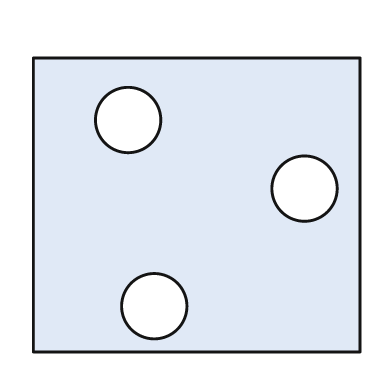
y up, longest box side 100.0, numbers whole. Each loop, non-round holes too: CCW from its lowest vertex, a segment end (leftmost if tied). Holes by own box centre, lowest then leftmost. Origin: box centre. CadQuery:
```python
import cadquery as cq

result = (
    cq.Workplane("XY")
    .moveTo(-50.0, -45.0)
    .lineTo(50.0, -45.0)
    .lineTo(50.0, 45.0)
    .lineTo(-50.0, 45.0)
    .close()
    .moveTo(-13.0, -31.0)
    .circle(10.0)
    .moveTo(33.0, 5.0)
    .circle(10.0)
    .moveTo(-21.0, 26.0)
    .circle(10.0)
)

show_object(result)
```